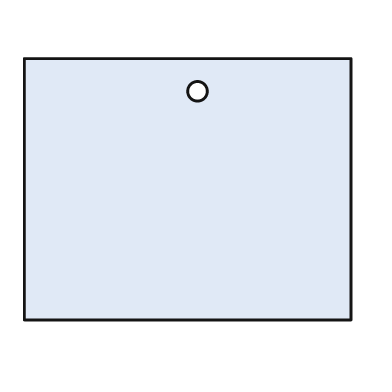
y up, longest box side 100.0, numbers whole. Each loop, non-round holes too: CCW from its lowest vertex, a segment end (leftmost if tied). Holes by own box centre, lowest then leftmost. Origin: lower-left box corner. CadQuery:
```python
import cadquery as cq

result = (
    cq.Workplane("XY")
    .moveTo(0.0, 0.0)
    .lineTo(100.0, 0.0)
    .lineTo(100.0, 80.0)
    .lineTo(0.0, 80.0)
    .close()
    .moveTo(53.0, 70.0)
    .circle(3.0)
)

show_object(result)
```